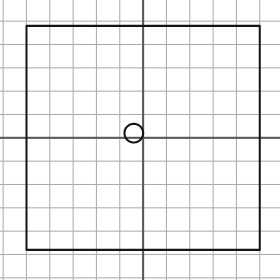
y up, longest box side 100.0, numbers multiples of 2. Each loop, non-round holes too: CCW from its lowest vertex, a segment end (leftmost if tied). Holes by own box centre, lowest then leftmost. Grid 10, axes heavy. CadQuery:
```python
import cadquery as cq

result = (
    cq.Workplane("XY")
    .moveTo(-50.0, -48.0)
    .lineTo(50.0, -48.0)
    .lineTo(50.0, 48.0)
    .lineTo(-50.0, 48.0)
    .close()
    .moveTo(-4.0, 2.0)
    .circle(4.0)
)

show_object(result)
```